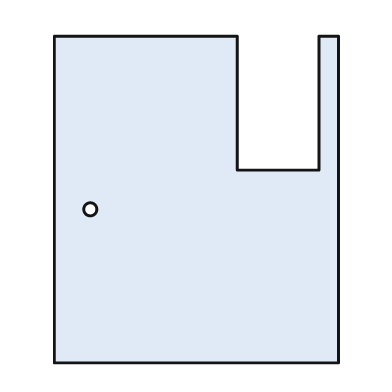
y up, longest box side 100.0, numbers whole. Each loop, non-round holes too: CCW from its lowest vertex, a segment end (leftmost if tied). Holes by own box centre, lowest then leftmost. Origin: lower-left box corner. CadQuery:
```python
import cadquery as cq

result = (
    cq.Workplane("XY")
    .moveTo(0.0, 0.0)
    .lineTo(87.0, 0.0)
    .lineTo(87.0, 100.0)
    .lineTo(81.0, 100.0)
    .lineTo(81.0, 59.0)
    .lineTo(56.0, 59.0)
    .lineTo(56.0, 100.0)
    .lineTo(0.0, 100.0)
    .close()
    .moveTo(11.0, 47.0)
    .circle(2.0)
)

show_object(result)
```